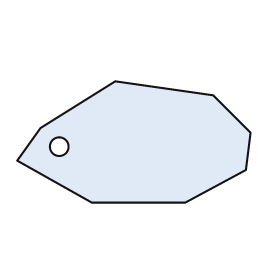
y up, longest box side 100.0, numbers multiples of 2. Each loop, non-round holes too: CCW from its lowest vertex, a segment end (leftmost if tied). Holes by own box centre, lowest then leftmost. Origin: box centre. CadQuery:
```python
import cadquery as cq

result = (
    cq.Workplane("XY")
    .moveTo(-18.0, -26.0)
    .lineTo(22.0, -26.0)
    .lineTo(48.0, -12.0)
    .lineTo(50.0, 4.0)
    .lineTo(34.0, 20.0)
    .lineTo(-8.0, 26.0)
    .lineTo(-40.0, 6.0)
    .lineTo(-50.0, -8.0)
    .close()
    .moveTo(-32.0, -2.0)
    .circle(4.0)
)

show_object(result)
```